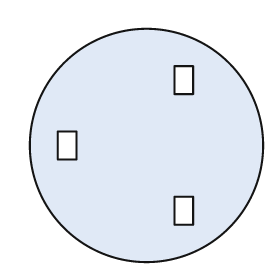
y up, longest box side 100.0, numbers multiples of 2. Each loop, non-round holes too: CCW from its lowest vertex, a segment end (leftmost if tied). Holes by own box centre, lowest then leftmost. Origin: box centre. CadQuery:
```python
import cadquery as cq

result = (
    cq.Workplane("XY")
    .moveTo(0.0, 0.0)
    .circle(50.0)
    .moveTo(12.0, -34.0)
    .lineTo(20.0, -34.0)
    .lineTo(20.0, -22.0)
    .lineTo(12.0, -22.0)
    .close()
    .moveTo(-38.0, -6.0)
    .lineTo(-30.0, -6.0)
    .lineTo(-30.0, 6.0)
    .lineTo(-38.0, 6.0)
    .close()
    .moveTo(12.0, 22.0)
    .lineTo(20.0, 22.0)
    .lineTo(20.0, 34.0)
    .lineTo(12.0, 34.0)
    .close()
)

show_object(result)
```